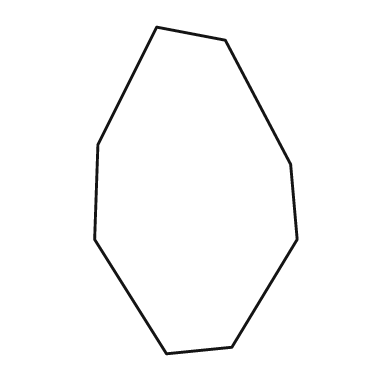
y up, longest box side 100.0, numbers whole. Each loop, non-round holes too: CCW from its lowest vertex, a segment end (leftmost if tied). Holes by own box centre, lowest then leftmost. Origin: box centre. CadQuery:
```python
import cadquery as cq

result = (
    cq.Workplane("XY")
    .moveTo(-9.0, -50.0)
    .lineTo(11.0, -48.0)
    .lineTo(31.0, -15.0)
    .lineTo(29.0, 8.0)
    .lineTo(9.0, 46.0)
    .lineTo(-12.0, 50.0)
    .lineTo(-30.0, 14.0)
    .lineTo(-31.0, -15.0)
    .close()
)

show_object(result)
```